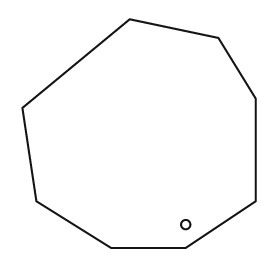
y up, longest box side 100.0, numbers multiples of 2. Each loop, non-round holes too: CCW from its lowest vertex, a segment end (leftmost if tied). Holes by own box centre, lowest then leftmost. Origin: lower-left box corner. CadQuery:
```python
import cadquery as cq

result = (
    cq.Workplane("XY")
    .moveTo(38.0, 0.0)
    .lineTo(70.0, 0.0)
    .lineTo(100.0, 20.0)
    .lineTo(100.0, 64.0)
    .lineTo(84.0, 90.0)
    .lineTo(46.0, 98.0)
    .lineTo(0.0, 60.0)
    .lineTo(6.0, 20.0)
    .close()
    .moveTo(70.0, 10.0)
    .circle(2.0)
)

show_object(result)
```